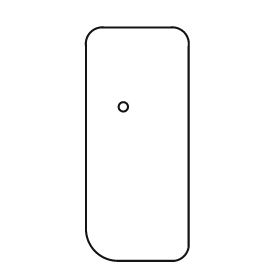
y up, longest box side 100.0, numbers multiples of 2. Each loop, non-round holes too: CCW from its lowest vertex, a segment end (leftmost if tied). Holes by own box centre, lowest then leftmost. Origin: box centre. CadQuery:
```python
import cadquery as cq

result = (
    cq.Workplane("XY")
    .moveTo(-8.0, -50.0)
    .lineTo(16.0, -50.0)
    .threePointArc((20.0, -48.0), (22.0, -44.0))
    .lineTo(22.0, 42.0)
    .threePointArc((20.0, 48.0), (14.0, 50.0))
    .lineTo(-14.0, 50.0)
    .threePointArc((-20.0, 48.0), (-22.0, 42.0))
    .lineTo(-22.0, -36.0)
    .threePointArc((-18.0, -46.0), (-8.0, -50.0))
    .close()
    .moveTo(-6.0, 16.0)
    .circle(2.0)
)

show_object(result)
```